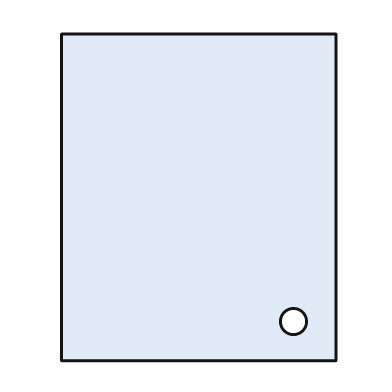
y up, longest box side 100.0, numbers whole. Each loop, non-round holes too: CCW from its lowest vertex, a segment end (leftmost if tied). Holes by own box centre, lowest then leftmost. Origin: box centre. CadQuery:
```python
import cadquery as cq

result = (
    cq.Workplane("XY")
    .moveTo(-42.0, -50.0)
    .lineTo(42.0, -50.0)
    .lineTo(42.0, 50.0)
    .lineTo(-42.0, 50.0)
    .close()
    .moveTo(29.0, -38.0)
    .circle(4.0)
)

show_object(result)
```